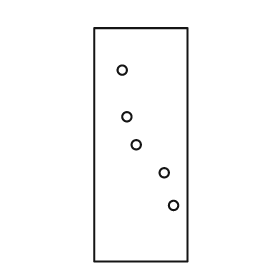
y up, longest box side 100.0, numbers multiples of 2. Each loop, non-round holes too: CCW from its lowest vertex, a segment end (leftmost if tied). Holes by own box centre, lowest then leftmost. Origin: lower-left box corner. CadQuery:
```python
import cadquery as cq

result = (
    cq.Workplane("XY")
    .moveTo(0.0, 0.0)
    .lineTo(40.0, 0.0)
    .lineTo(40.0, 100.0)
    .lineTo(0.0, 100.0)
    .close()
    .moveTo(34.0, 24.0)
    .circle(2.0)
    .moveTo(30.0, 38.0)
    .circle(2.0)
    .moveTo(18.0, 50.0)
    .circle(2.0)
    .moveTo(14.0, 62.0)
    .circle(2.0)
    .moveTo(12.0, 82.0)
    .circle(2.0)
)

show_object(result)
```